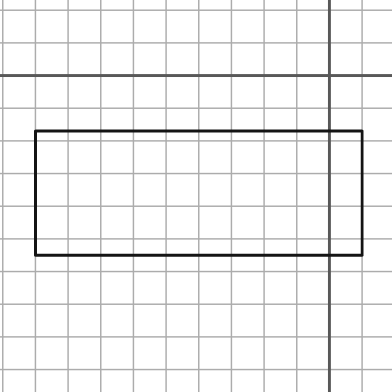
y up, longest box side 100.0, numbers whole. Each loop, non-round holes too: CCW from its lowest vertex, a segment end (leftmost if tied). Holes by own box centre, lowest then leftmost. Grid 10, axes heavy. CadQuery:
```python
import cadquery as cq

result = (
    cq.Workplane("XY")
    .moveTo(-90.0, -55.0)
    .lineTo(10.0, -55.0)
    .lineTo(10.0, -17.0)
    .lineTo(-90.0, -17.0)
    .close()
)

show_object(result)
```